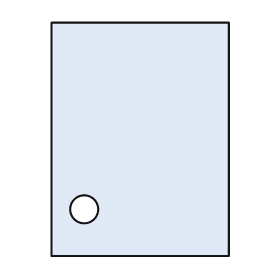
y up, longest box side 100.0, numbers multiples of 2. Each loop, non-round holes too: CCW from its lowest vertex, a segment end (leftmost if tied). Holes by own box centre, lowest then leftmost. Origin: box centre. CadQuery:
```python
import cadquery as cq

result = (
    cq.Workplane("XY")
    .moveTo(-38.0, -50.0)
    .lineTo(38.0, -50.0)
    .lineTo(38.0, 50.0)
    .lineTo(-38.0, 50.0)
    .close()
    .moveTo(-24.0, -30.0)
    .circle(6.0)
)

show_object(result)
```